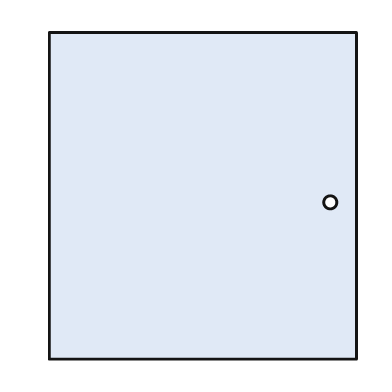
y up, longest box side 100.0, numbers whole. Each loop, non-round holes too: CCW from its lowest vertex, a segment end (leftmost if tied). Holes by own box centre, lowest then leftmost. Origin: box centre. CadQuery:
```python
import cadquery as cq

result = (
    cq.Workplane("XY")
    .moveTo(-47.0, -50.0)
    .lineTo(47.0, -50.0)
    .lineTo(47.0, 50.0)
    .lineTo(-47.0, 50.0)
    .close()
    .moveTo(39.0, -2.0)
    .circle(2.0)
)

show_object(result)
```